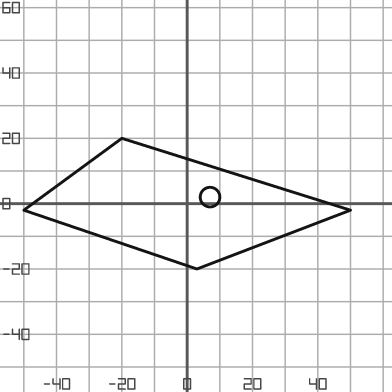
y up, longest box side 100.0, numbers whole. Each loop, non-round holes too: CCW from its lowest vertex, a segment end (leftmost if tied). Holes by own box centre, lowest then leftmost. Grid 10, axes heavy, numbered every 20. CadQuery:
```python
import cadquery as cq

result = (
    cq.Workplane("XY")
    .moveTo(3.0, -20.0)
    .lineTo(50.0, -2.0)
    .lineTo(-20.0, 20.0)
    .lineTo(-50.0, -2.0)
    .close()
    .moveTo(7.0, 2.0)
    .circle(3.0)
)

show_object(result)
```